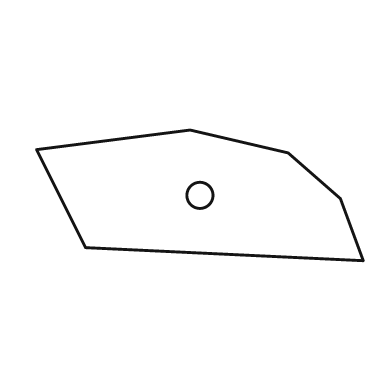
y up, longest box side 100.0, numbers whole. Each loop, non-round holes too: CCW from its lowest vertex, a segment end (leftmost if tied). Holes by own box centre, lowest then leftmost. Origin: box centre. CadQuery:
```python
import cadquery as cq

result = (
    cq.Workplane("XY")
    .moveTo(50.0, -20.0)
    .lineTo(43.0, -1.0)
    .lineTo(27.0, 13.0)
    .lineTo(-3.0, 20.0)
    .lineTo(-50.0, 14.0)
    .lineTo(-35.0, -16.0)
    .close()
    .moveTo(0.0, 0.0)
    .circle(4.0)
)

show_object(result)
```